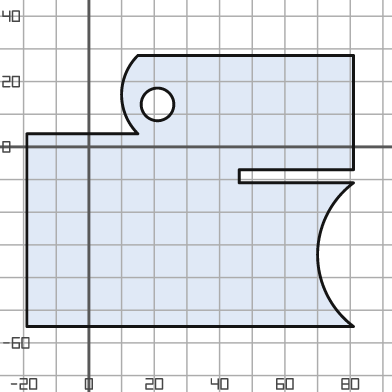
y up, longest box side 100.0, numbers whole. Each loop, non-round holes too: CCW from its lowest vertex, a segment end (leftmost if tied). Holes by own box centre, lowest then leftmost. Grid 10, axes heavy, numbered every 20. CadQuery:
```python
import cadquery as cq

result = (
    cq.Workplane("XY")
    .moveTo(-19.0, -55.0)
    .lineTo(81.0, -55.0)
    .threePointArc((70.0, -33.0), (81.0, -11.0))
    .lineTo(46.0, -11.0)
    .lineTo(46.0, -7.0)
    .lineTo(81.0, -7.0)
    .lineTo(81.0, 28.0)
    .lineTo(15.0, 28.0)
    .threePointArc((10.0, 16.0), (15.0, 4.0))
    .lineTo(-19.0, 4.0)
    .close()
    .moveTo(21.0, 13.0)
    .circle(5.0)
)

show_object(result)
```